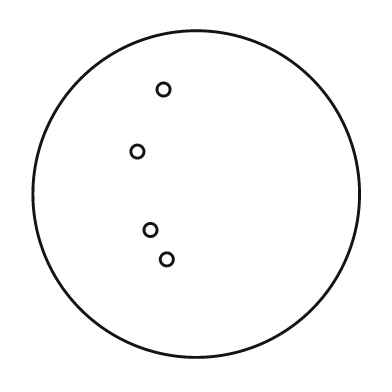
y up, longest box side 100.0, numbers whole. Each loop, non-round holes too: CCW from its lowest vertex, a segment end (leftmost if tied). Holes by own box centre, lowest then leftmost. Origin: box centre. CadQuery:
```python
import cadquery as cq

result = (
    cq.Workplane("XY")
    .moveTo(0.0, 0.0)
    .circle(50.0)
    .moveTo(-9.0, -20.0)
    .circle(2.0)
    .moveTo(-14.0, -11.0)
    .circle(2.0)
    .moveTo(-18.0, 13.0)
    .circle(2.0)
    .moveTo(-10.0, 32.0)
    .circle(2.0)
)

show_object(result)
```